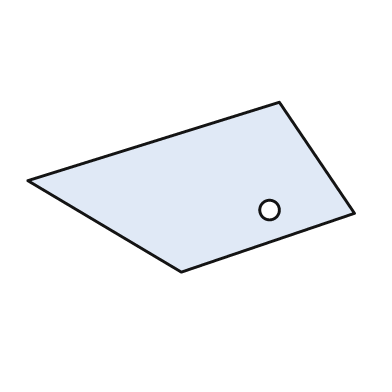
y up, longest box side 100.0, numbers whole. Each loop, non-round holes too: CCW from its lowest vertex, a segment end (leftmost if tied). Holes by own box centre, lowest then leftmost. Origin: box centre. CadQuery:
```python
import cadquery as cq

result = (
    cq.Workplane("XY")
    .moveTo(-3.0, -26.0)
    .lineTo(50.0, -8.0)
    .lineTo(27.0, 26.0)
    .lineTo(-50.0, 2.0)
    .close()
    .moveTo(24.0, -7.0)
    .circle(3.0)
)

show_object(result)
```